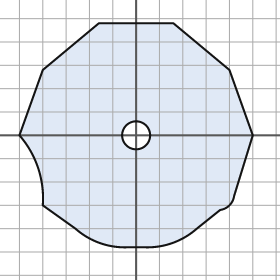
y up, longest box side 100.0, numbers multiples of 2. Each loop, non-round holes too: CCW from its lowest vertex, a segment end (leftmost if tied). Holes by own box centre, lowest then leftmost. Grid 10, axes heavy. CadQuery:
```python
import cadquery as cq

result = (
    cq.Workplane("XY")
    .moveTo(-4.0, -48.0)
    .lineTo(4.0, -48.0)
    .threePointArc((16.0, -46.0), (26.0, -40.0))
    .lineTo(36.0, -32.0)
    .threePointArc((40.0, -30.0), (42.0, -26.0))
    .lineTo(50.0, 0.0)
    .lineTo(40.0, 28.0)
    .lineTo(16.0, 48.0)
    .lineTo(-16.0, 48.0)
    .lineTo(-40.0, 28.0)
    .lineTo(-50.0, 0.0)
    .threePointArc((-42.0, -14.0), (-40.0, -30.0))
    .lineTo(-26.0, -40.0)
    .threePointArc((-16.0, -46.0), (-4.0, -48.0))
    .close()
    .moveTo(0.0, 0.0)
    .circle(6.0)
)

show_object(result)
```